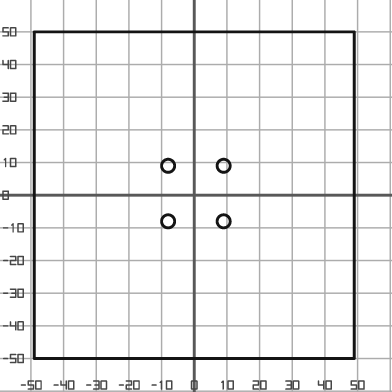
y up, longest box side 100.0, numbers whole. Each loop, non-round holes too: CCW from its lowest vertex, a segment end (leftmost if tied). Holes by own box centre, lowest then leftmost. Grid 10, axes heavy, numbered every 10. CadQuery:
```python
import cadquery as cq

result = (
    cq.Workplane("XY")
    .moveTo(-49.0, -50.0)
    .lineTo(49.0, -50.0)
    .lineTo(49.0, 50.0)
    .lineTo(-49.0, 50.0)
    .close()
    .moveTo(-8.0, -8.0)
    .circle(2.0)
    .moveTo(9.0, -8.0)
    .circle(2.0)
    .moveTo(-8.0, 9.0)
    .circle(2.0)
    .moveTo(9.0, 9.0)
    .circle(2.0)
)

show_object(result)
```